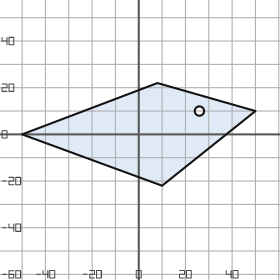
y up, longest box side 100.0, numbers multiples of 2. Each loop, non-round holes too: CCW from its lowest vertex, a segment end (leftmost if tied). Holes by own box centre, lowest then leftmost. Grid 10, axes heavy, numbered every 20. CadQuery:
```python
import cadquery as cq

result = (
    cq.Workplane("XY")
    .moveTo(10.0, -22.0)
    .lineTo(50.0, 10.0)
    .lineTo(8.0, 22.0)
    .lineTo(-50.0, 0.0)
    .close()
    .moveTo(26.0, 10.0)
    .circle(2.0)
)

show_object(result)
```